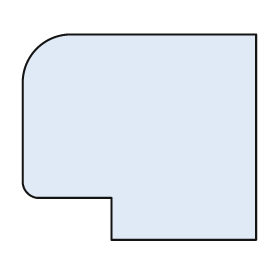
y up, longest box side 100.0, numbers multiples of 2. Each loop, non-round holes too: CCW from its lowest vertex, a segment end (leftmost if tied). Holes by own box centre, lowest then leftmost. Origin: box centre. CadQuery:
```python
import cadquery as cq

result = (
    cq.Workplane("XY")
    .moveTo(-12.0, -44.0)
    .lineTo(50.0, -44.0)
    .lineTo(50.0, 44.0)
    .lineTo(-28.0, 44.0)
    .threePointArc((-44.0, 38.0), (-50.0, 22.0))
    .lineTo(-50.0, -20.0)
    .threePointArc((-48.0, -24.0), (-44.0, -26.0))
    .lineTo(-12.0, -26.0)
    .close()
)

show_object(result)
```